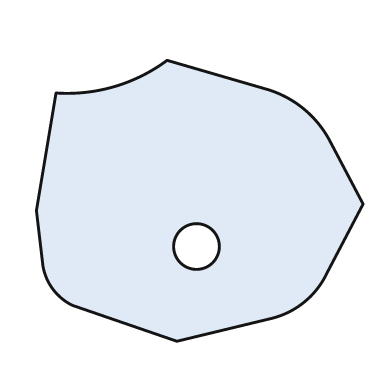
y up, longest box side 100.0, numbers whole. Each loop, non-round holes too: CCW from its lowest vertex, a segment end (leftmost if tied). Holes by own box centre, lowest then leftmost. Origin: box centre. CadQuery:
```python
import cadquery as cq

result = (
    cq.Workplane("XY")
    .moveTo(-7.0, -43.0)
    .lineTo(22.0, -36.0)
    .threePointArc((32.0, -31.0), (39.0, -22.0))
    .lineTo(50.0, -1.0)
    .lineTo(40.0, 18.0)
    .threePointArc((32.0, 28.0), (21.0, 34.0))
    .lineTo(-10.0, 43.0)
    .threePointArc((-26.0, 35.0), (-44.0, 33.0))
    .lineTo(-50.0, -3.0)
    .lineTo(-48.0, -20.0)
    .threePointArc((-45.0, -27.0), (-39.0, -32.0))
    .close()
    .moveTo(-1.0, -14.0)
    .circle(7.0)
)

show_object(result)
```